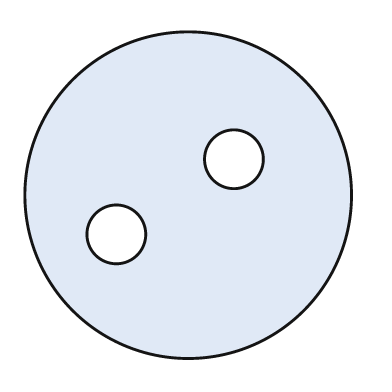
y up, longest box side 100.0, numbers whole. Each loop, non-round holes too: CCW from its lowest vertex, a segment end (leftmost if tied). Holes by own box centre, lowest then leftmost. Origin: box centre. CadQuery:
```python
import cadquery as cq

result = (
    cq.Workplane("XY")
    .moveTo(0.0, 0.0)
    .circle(50.0)
    .moveTo(-22.0, -12.0)
    .circle(9.0)
    .moveTo(14.0, 11.0)
    .circle(9.0)
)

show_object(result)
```